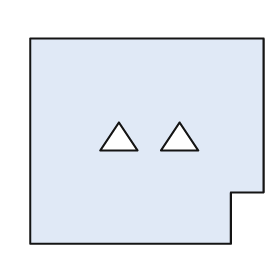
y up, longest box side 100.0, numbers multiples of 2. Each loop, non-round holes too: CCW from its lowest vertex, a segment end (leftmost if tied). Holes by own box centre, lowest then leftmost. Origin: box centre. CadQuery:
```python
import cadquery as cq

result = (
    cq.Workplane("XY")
    .moveTo(-50.0, -44.0)
    .lineTo(36.0, -44.0)
    .lineTo(36.0, -22.0)
    .lineTo(50.0, -22.0)
    .lineTo(50.0, 44.0)
    .lineTo(-50.0, 44.0)
    .close()
    .moveTo(-20.0, -4.0)
    .lineTo(-4.0, -4.0)
    .lineTo(-12.0, 8.0)
    .close()
    .moveTo(6.0, -4.0)
    .lineTo(22.0, -4.0)
    .lineTo(14.0, 8.0)
    .close()
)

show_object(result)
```